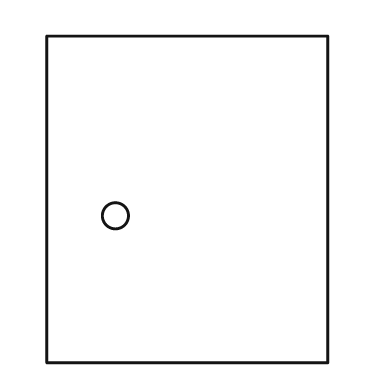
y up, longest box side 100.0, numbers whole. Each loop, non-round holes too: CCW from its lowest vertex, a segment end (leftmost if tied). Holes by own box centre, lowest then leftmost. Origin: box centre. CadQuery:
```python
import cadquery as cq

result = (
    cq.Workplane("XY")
    .moveTo(-43.0, -50.0)
    .lineTo(43.0, -50.0)
    .lineTo(43.0, 50.0)
    .lineTo(-43.0, 50.0)
    .close()
    .moveTo(-22.0, -5.0)
    .circle(4.0)
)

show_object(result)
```